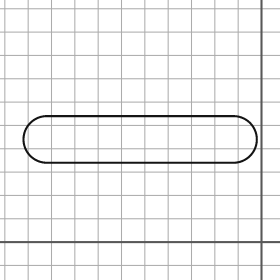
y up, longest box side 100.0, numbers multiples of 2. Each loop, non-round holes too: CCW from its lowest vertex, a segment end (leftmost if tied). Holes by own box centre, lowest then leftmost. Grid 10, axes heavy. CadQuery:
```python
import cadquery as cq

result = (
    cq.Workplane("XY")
    .moveTo(-92.0, 34.0)
    .lineTo(-12.0, 34.0)
    .threePointArc((-2.0, 44.0), (-12.0, 54.0))
    .lineTo(-92.0, 54.0)
    .threePointArc((-102.0, 44.0), (-92.0, 34.0))
    .close()
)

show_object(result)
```